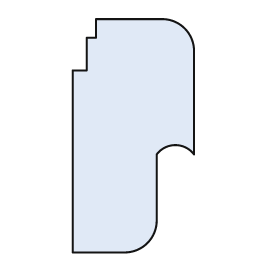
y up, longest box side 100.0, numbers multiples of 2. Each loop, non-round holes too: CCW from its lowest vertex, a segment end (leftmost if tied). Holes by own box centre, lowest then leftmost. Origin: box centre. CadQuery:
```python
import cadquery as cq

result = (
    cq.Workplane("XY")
    .moveTo(-26.0, -50.0)
    .lineTo(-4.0, -50.0)
    .threePointArc((6.0, -46.0), (10.0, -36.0))
    .lineTo(10.0, -8.0)
    .threePointArc((18.0, -4.0), (26.0, -8.0))
    .lineTo(26.0, 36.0)
    .threePointArc((22.0, 46.0), (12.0, 50.0))
    .lineTo(-16.0, 50.0)
    .lineTo(-16.0, 42.0)
    .lineTo(-20.0, 42.0)
    .lineTo(-20.0, 28.0)
    .lineTo(-26.0, 28.0)
    .close()
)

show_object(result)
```